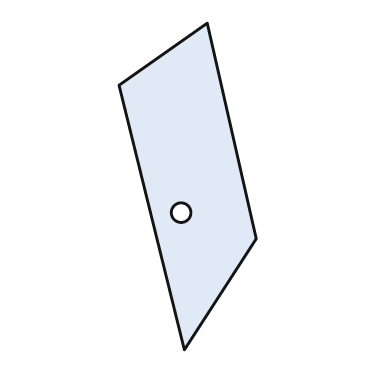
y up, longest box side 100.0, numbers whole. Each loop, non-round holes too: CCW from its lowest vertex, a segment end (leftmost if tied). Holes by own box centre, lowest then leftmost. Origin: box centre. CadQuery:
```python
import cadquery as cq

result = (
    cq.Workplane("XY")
    .moveTo(-1.0, -50.0)
    .lineTo(21.0, -16.0)
    .lineTo(6.0, 50.0)
    .lineTo(-21.0, 31.0)
    .close()
    .moveTo(-2.0, -8.0)
    .circle(3.0)
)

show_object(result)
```